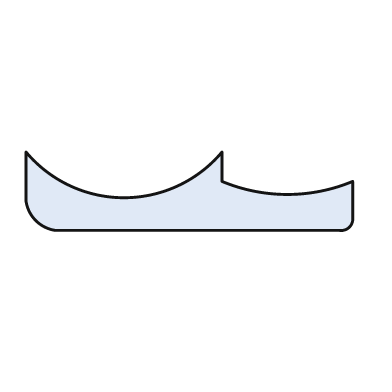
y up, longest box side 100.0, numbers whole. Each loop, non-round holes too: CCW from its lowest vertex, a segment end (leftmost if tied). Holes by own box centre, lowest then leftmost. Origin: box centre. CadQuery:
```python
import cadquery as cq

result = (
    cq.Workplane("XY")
    .moveTo(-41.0, -12.0)
    .lineTo(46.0, -12.0)
    .threePointArc((49.0, -11.0), (50.0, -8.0))
    .lineTo(50.0, 3.0)
    .threePointArc((30.0, -1.0), (10.0, 3.0))
    .lineTo(10.0, 12.0)
    .threePointArc((-20.0, -2.0), (-50.0, 12.0))
    .lineTo(-50.0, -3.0)
    .threePointArc((-47.0, -9.0), (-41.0, -12.0))
    .close()
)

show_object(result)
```